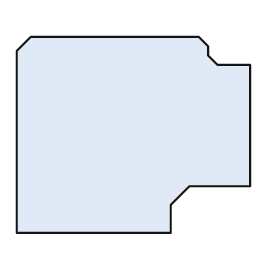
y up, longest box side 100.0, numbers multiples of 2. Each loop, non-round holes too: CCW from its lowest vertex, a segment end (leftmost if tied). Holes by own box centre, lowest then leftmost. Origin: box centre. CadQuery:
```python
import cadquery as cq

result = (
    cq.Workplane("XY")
    .moveTo(-50.0, -42.0)
    .lineTo(16.0, -42.0)
    .lineTo(16.0, -30.0)
    .lineTo(24.0, -22.0)
    .lineTo(50.0, -22.0)
    .lineTo(50.0, 30.0)
    .lineTo(36.0, 30.0)
    .lineTo(32.0, 34.0)
    .lineTo(32.0, 38.0)
    .lineTo(28.0, 42.0)
    .lineTo(-44.0, 42.0)
    .lineTo(-50.0, 36.0)
    .close()
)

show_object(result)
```